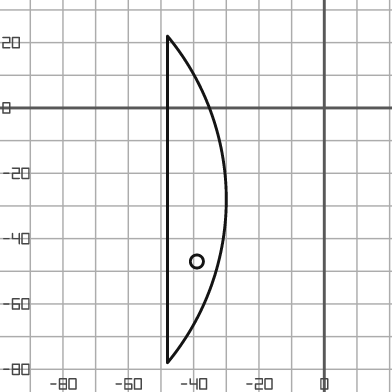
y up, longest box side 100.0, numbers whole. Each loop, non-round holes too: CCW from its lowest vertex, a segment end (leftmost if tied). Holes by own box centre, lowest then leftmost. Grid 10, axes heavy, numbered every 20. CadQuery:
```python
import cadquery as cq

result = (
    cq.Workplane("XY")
    .moveTo(-48.0, -78.0)
    .threePointArc((-30.0, -28.0), (-48.0, 22.0))
    .close()
    .moveTo(-39.0, -47.0)
    .circle(2.0)
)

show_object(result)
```